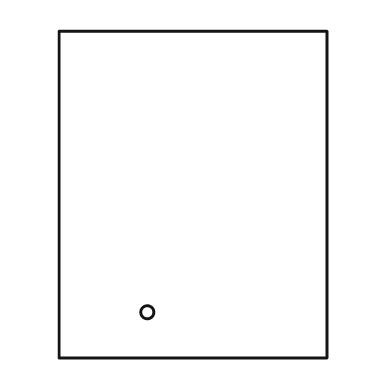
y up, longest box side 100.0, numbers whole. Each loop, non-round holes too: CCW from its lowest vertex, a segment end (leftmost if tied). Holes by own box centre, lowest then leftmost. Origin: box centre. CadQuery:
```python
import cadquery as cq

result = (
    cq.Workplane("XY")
    .moveTo(-41.0, -50.0)
    .lineTo(41.0, -50.0)
    .lineTo(41.0, 50.0)
    .lineTo(-41.0, 50.0)
    .close()
    .moveTo(-14.0, -36.0)
    .circle(2.0)
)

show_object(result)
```